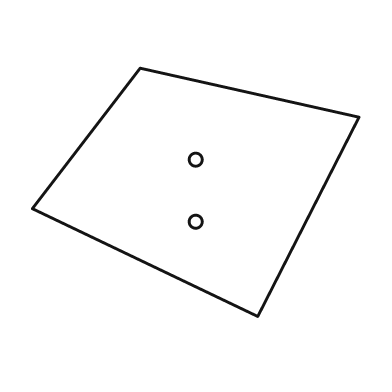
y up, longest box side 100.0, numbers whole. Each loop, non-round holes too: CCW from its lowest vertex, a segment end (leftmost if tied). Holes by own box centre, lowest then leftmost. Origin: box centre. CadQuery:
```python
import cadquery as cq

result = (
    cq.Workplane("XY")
    .moveTo(19.0, -38.0)
    .lineTo(50.0, 23.0)
    .lineTo(-17.0, 38.0)
    .lineTo(-50.0, -5.0)
    .close()
    .moveTo(0.0, -9.0)
    .circle(2.0)
    .moveTo(0.0, 10.0)
    .circle(2.0)
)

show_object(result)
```